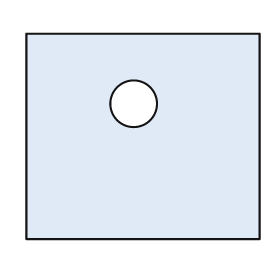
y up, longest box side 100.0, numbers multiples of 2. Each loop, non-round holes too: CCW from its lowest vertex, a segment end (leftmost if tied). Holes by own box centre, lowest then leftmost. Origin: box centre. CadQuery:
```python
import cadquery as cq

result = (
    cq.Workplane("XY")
    .moveTo(-50.0, -44.0)
    .lineTo(50.0, -44.0)
    .lineTo(50.0, 44.0)
    .lineTo(-50.0, 44.0)
    .close()
    .moveTo(-4.0, 14.0)
    .circle(10.0)
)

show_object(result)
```